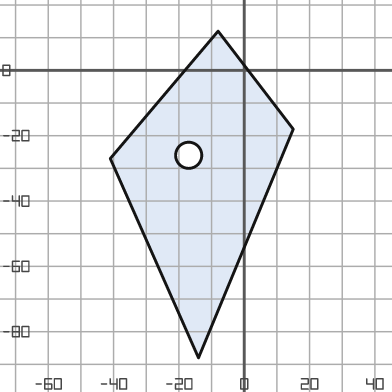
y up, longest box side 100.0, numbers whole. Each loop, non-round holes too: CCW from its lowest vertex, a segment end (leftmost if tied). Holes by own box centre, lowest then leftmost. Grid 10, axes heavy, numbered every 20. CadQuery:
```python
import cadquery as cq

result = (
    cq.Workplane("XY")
    .moveTo(-14.0, -88.0)
    .lineTo(15.0, -18.0)
    .lineTo(-8.0, 12.0)
    .lineTo(-41.0, -27.0)
    .close()
    .moveTo(-17.0, -26.0)
    .circle(4.0)
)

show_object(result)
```